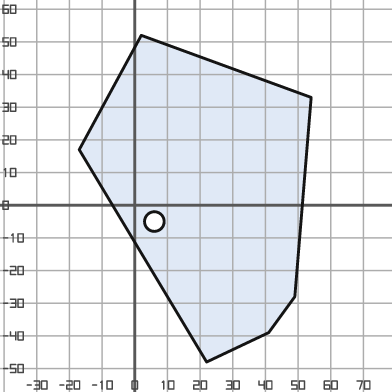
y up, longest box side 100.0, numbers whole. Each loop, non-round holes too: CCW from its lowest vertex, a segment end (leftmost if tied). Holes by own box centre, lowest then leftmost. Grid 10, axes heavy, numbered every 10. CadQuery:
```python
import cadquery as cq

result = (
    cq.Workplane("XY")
    .moveTo(22.0, -48.0)
    .lineTo(41.0, -39.0)
    .lineTo(49.0, -28.0)
    .lineTo(54.0, 33.0)
    .lineTo(2.0, 52.0)
    .lineTo(-17.0, 17.0)
    .close()
    .moveTo(6.0, -5.0)
    .circle(3.0)
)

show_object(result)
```